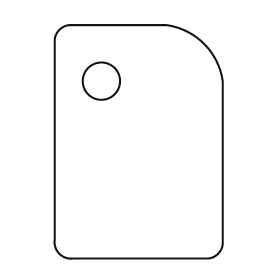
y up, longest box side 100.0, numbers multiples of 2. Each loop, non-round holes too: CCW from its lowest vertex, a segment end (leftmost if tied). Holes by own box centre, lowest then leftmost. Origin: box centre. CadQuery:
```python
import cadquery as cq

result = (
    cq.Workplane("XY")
    .moveTo(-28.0, -50.0)
    .lineTo(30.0, -50.0)
    .threePointArc((34.0, -48.0), (36.0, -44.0))
    .lineTo(36.0, 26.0)
    .threePointArc((28.0, 42.0), (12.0, 50.0))
    .lineTo(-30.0, 50.0)
    .threePointArc((-34.0, 48.0), (-36.0, 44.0))
    .lineTo(-36.0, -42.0)
    .threePointArc((-34.0, -48.0), (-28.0, -50.0))
    .close()
    .moveTo(-16.0, 26.0)
    .circle(8.0)
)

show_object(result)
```